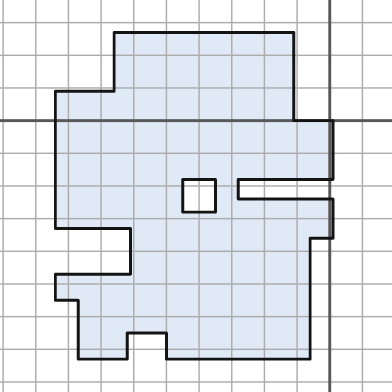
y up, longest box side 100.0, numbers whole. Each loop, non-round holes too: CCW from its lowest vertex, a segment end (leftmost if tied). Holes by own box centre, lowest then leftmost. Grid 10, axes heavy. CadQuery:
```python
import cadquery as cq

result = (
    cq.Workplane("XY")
    .moveTo(-77.0, -73.0)
    .lineTo(-62.0, -73.0)
    .lineTo(-62.0, -65.0)
    .lineTo(-50.0, -65.0)
    .lineTo(-50.0, -73.0)
    .lineTo(-6.0, -73.0)
    .lineTo(-6.0, -36.0)
    .lineTo(1.0, -36.0)
    .lineTo(1.0, -24.0)
    .lineTo(-28.0, -24.0)
    .lineTo(-28.0, -18.0)
    .lineTo(1.0, -18.0)
    .lineTo(1.0, 0.0)
    .lineTo(-11.0, 0.0)
    .lineTo(-11.0, 27.0)
    .lineTo(-66.0, 27.0)
    .lineTo(-66.0, 9.0)
    .lineTo(-84.0, 9.0)
    .lineTo(-84.0, -33.0)
    .lineTo(-61.0, -33.0)
    .lineTo(-61.0, -47.0)
    .lineTo(-84.0, -47.0)
    .lineTo(-84.0, -55.0)
    .lineTo(-77.0, -55.0)
    .close()
    .moveTo(-45.0, -28.0)
    .lineTo(-35.0, -28.0)
    .lineTo(-35.0, -18.0)
    .lineTo(-45.0, -18.0)
    .close()
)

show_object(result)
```